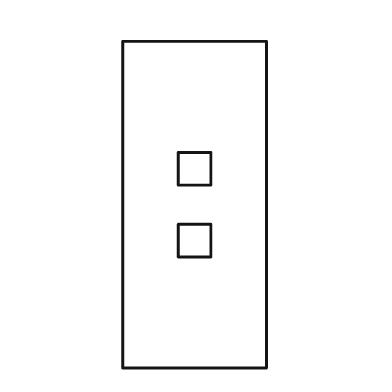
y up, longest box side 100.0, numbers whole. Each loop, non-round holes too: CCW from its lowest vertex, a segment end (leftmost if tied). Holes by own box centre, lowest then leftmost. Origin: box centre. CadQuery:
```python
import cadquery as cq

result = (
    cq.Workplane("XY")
    .moveTo(-22.0, -50.0)
    .lineTo(22.0, -50.0)
    .lineTo(22.0, 50.0)
    .lineTo(-22.0, 50.0)
    .close()
    .moveTo(-5.0, -16.0)
    .lineTo(5.0, -16.0)
    .lineTo(5.0, -6.0)
    .lineTo(-5.0, -6.0)
    .close()
    .moveTo(-5.0, 6.0)
    .lineTo(5.0, 6.0)
    .lineTo(5.0, 16.0)
    .lineTo(-5.0, 16.0)
    .close()
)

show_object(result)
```